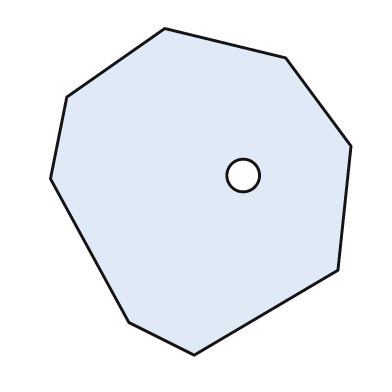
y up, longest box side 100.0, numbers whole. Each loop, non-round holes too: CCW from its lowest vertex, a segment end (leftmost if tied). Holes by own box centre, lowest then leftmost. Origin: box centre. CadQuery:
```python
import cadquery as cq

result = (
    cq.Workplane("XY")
    .moveTo(-2.0, -50.0)
    .lineTo(42.0, -24.0)
    .lineTo(46.0, 14.0)
    .lineTo(26.0, 41.0)
    .lineTo(-11.0, 50.0)
    .lineTo(-41.0, 29.0)
    .lineTo(-46.0, 4.0)
    .lineTo(-22.0, -40.0)
    .close()
    .moveTo(13.0, 5.0)
    .circle(5.0)
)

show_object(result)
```